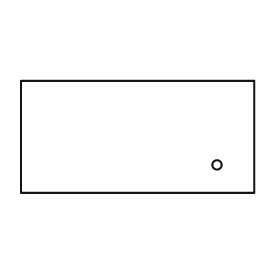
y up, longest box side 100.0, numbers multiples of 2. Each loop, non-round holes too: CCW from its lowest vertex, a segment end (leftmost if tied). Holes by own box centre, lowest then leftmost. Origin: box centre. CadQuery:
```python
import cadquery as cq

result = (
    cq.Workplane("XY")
    .moveTo(-50.0, -24.0)
    .lineTo(50.0, -24.0)
    .lineTo(50.0, 24.0)
    .lineTo(-50.0, 24.0)
    .close()
    .moveTo(34.0, -12.0)
    .circle(2.0)
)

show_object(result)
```